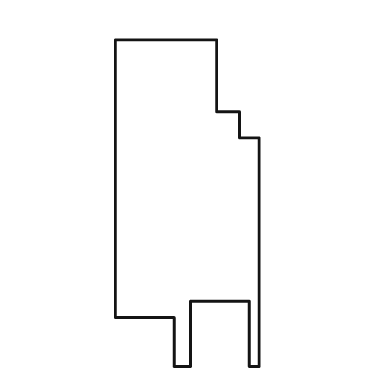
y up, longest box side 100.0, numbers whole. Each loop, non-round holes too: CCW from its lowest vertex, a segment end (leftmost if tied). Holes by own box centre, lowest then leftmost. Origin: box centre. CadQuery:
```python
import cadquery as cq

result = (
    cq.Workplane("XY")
    .moveTo(-4.0, -50.0)
    .lineTo(1.0, -50.0)
    .lineTo(1.0, -30.0)
    .lineTo(19.0, -30.0)
    .lineTo(19.0, -50.0)
    .lineTo(22.0, -50.0)
    .lineTo(22.0, 20.0)
    .lineTo(16.0, 20.0)
    .lineTo(16.0, 28.0)
    .lineTo(9.0, 28.0)
    .lineTo(9.0, 50.0)
    .lineTo(-22.0, 50.0)
    .lineTo(-22.0, -35.0)
    .lineTo(-4.0, -35.0)
    .close()
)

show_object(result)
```